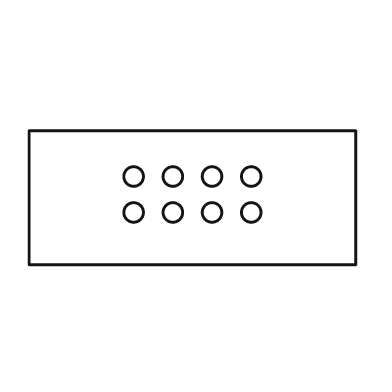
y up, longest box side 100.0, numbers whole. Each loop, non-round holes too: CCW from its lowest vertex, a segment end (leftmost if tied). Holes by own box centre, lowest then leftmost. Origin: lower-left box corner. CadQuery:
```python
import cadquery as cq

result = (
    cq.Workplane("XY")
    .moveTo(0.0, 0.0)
    .lineTo(100.0, 0.0)
    .lineTo(100.0, 41.0)
    .lineTo(0.0, 41.0)
    .close()
    .moveTo(32.0, 16.0)
    .circle(3.0)
    .moveTo(44.0, 16.0)
    .circle(3.0)
    .moveTo(56.0, 16.0)
    .circle(3.0)
    .moveTo(68.0, 16.0)
    .circle(3.0)
    .moveTo(32.0, 27.0)
    .circle(3.0)
    .moveTo(44.0, 27.0)
    .circle(3.0)
    .moveTo(56.0, 27.0)
    .circle(3.0)
    .moveTo(68.0, 27.0)
    .circle(3.0)
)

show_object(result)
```